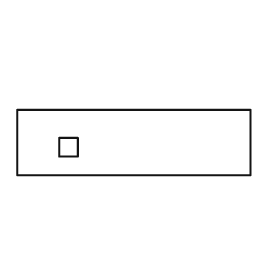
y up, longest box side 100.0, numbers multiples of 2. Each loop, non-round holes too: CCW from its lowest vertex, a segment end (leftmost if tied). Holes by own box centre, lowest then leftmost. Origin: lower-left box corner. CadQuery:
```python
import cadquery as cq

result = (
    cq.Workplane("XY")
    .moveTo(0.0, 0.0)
    .lineTo(100.0, 0.0)
    .lineTo(100.0, 28.0)
    .lineTo(0.0, 28.0)
    .close()
    .moveTo(18.0, 8.0)
    .lineTo(26.0, 8.0)
    .lineTo(26.0, 16.0)
    .lineTo(18.0, 16.0)
    .close()
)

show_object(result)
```